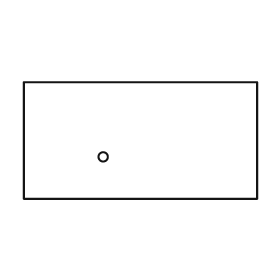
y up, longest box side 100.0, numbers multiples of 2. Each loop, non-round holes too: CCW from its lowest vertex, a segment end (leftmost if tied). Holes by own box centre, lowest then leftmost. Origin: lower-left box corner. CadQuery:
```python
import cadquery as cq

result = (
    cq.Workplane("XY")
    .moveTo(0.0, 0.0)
    .lineTo(100.0, 0.0)
    .lineTo(100.0, 50.0)
    .lineTo(0.0, 50.0)
    .close()
    .moveTo(34.0, 18.0)
    .circle(2.0)
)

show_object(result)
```